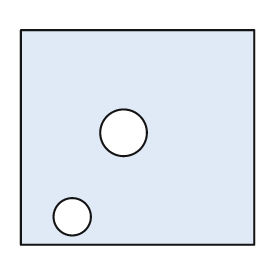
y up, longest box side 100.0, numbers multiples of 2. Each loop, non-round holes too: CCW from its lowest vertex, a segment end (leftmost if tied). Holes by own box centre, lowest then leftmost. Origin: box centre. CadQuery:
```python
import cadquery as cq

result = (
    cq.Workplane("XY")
    .moveTo(-50.0, -46.0)
    .lineTo(50.0, -46.0)
    .lineTo(50.0, 46.0)
    .lineTo(-50.0, 46.0)
    .close()
    .moveTo(-28.0, -34.0)
    .circle(8.0)
    .moveTo(-6.0, 2.0)
    .circle(10.0)
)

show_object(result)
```